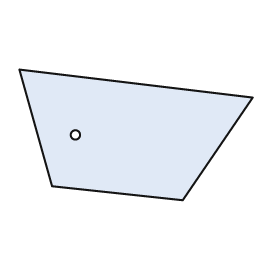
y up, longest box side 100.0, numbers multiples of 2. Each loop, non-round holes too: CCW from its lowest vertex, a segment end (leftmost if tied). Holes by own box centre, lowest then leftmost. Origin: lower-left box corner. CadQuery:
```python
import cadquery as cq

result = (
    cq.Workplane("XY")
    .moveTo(70.0, 0.0)
    .lineTo(100.0, 44.0)
    .lineTo(0.0, 56.0)
    .lineTo(14.0, 6.0)
    .close()
    .moveTo(24.0, 28.0)
    .circle(2.0)
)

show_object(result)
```